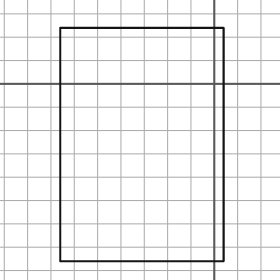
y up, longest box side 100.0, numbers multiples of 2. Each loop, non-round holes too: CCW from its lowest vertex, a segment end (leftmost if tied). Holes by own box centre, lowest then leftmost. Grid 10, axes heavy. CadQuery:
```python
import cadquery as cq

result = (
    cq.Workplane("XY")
    .moveTo(-66.0, -76.0)
    .lineTo(4.0, -76.0)
    .lineTo(4.0, 24.0)
    .lineTo(-66.0, 24.0)
    .close()
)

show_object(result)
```